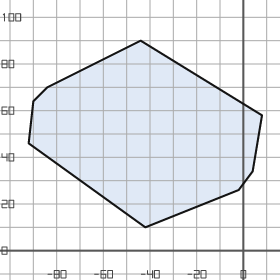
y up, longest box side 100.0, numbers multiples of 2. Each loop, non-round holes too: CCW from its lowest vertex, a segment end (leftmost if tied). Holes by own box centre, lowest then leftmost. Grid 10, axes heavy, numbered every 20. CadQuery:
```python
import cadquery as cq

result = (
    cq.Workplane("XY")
    .moveTo(-42.0, 10.0)
    .lineTo(-2.0, 26.0)
    .lineTo(4.0, 34.0)
    .lineTo(8.0, 58.0)
    .lineTo(-44.0, 90.0)
    .lineTo(-84.0, 70.0)
    .lineTo(-90.0, 64.0)
    .lineTo(-92.0, 46.0)
    .close()
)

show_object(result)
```